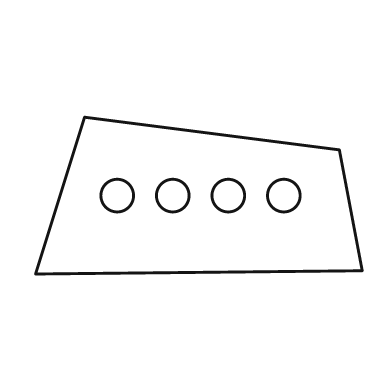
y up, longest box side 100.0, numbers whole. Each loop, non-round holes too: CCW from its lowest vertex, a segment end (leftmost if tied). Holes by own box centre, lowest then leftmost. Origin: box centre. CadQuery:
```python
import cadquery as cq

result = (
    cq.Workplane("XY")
    .moveTo(-50.0, -24.0)
    .lineTo(50.0, -23.0)
    .lineTo(43.0, 14.0)
    .lineTo(-35.0, 24.0)
    .close()
    .moveTo(-25.0, 0.0)
    .circle(5.0)
    .moveTo(-8.0, 0.0)
    .circle(5.0)
    .moveTo(9.0, 0.0)
    .circle(5.0)
    .moveTo(26.0, 0.0)
    .circle(5.0)
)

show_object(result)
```